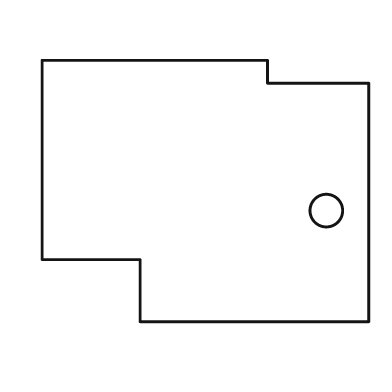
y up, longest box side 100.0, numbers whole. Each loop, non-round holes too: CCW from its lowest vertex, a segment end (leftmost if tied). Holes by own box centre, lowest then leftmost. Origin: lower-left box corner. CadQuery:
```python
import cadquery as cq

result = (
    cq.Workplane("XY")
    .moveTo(30.0, 0.0)
    .lineTo(100.0, 0.0)
    .lineTo(100.0, 73.0)
    .lineTo(69.0, 73.0)
    .lineTo(69.0, 80.0)
    .lineTo(0.0, 80.0)
    .lineTo(0.0, 19.0)
    .lineTo(30.0, 19.0)
    .close()
    .moveTo(87.0, 34.0)
    .circle(5.0)
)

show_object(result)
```